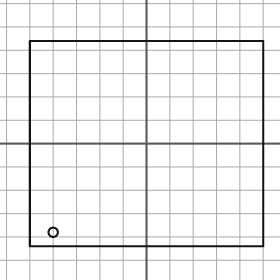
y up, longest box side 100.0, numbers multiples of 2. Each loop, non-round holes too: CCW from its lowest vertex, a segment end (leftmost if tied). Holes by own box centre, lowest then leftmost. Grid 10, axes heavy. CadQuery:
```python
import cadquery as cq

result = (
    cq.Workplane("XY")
    .moveTo(-50.0, -44.0)
    .lineTo(50.0, -44.0)
    .lineTo(50.0, 44.0)
    .lineTo(-50.0, 44.0)
    .close()
    .moveTo(-40.0, -38.0)
    .circle(2.0)
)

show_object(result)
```